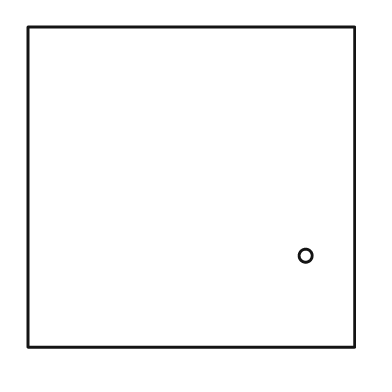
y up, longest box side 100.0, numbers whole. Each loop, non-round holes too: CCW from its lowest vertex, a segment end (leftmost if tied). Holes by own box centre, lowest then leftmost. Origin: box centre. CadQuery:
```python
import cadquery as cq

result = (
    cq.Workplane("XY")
    .moveTo(-50.0, -49.0)
    .lineTo(50.0, -49.0)
    .lineTo(50.0, 49.0)
    .lineTo(-50.0, 49.0)
    .close()
    .moveTo(35.0, -21.0)
    .circle(2.0)
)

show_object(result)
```